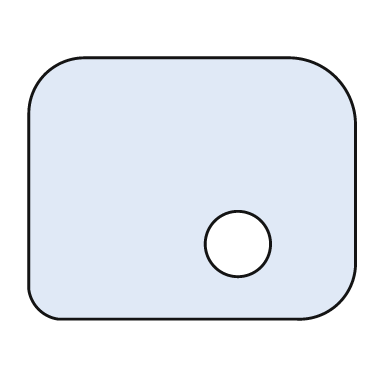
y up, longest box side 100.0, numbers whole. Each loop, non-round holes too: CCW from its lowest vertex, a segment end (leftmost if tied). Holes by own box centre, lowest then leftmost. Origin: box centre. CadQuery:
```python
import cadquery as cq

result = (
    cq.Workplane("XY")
    .moveTo(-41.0, -40.0)
    .lineTo(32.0, -40.0)
    .threePointArc((45.0, -35.0), (50.0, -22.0))
    .lineTo(50.0, 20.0)
    .threePointArc((44.0, 34.0), (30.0, 40.0))
    .lineTo(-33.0, 40.0)
    .threePointArc((-45.0, 35.0), (-50.0, 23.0))
    .lineTo(-50.0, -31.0)
    .threePointArc((-47.0, -37.0), (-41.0, -40.0))
    .close()
    .moveTo(14.0, -17.0)
    .circle(10.0)
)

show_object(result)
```